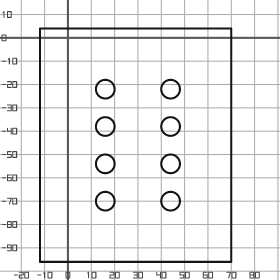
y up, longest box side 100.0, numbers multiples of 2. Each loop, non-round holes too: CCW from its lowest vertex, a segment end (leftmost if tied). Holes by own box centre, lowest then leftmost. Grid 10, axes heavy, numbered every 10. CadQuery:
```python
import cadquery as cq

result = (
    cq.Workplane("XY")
    .moveTo(-12.0, -96.0)
    .lineTo(70.0, -96.0)
    .lineTo(70.0, 4.0)
    .lineTo(-12.0, 4.0)
    .close()
    .moveTo(16.0, -70.0)
    .circle(4.0)
    .moveTo(44.0, -70.0)
    .circle(4.0)
    .moveTo(16.0, -54.0)
    .circle(4.0)
    .moveTo(44.0, -54.0)
    .circle(4.0)
    .moveTo(16.0, -38.0)
    .circle(4.0)
    .moveTo(44.0, -38.0)
    .circle(4.0)
    .moveTo(16.0, -22.0)
    .circle(4.0)
    .moveTo(44.0, -22.0)
    .circle(4.0)
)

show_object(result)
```